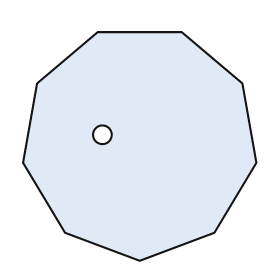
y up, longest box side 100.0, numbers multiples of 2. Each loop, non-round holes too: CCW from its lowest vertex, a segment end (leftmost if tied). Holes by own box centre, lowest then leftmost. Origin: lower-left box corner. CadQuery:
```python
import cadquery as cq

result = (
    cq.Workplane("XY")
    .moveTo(50.0, 0.0)
    .lineTo(82.0, 12.0)
    .lineTo(100.0, 42.0)
    .lineTo(94.0, 76.0)
    .lineTo(68.0, 98.0)
    .lineTo(32.0, 98.0)
    .lineTo(6.0, 76.0)
    .lineTo(0.0, 42.0)
    .lineTo(18.0, 12.0)
    .close()
    .moveTo(34.0, 54.0)
    .circle(4.0)
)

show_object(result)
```